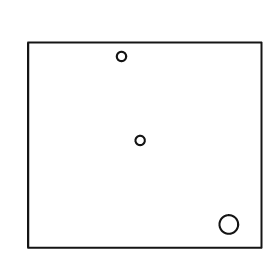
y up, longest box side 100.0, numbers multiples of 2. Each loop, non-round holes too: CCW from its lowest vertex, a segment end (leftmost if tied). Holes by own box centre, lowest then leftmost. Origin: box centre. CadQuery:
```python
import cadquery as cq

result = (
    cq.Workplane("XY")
    .moveTo(-50.0, -44.0)
    .lineTo(50.0, -44.0)
    .lineTo(50.0, 44.0)
    .lineTo(-50.0, 44.0)
    .close()
    .moveTo(36.0, -34.0)
    .circle(4.0)
    .moveTo(-2.0, 2.0)
    .circle(2.0)
    .moveTo(-10.0, 38.0)
    .circle(2.0)
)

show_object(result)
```